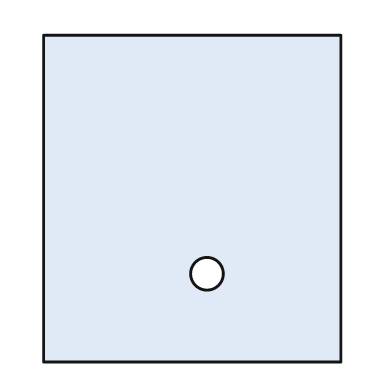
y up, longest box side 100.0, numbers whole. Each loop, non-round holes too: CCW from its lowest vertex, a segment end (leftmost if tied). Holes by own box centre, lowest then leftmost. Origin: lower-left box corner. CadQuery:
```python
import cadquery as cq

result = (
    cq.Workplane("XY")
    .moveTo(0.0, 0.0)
    .lineTo(91.0, 0.0)
    .lineTo(91.0, 100.0)
    .lineTo(0.0, 100.0)
    .close()
    .moveTo(50.0, 27.0)
    .circle(5.0)
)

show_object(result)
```